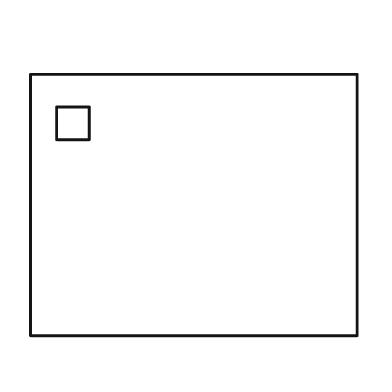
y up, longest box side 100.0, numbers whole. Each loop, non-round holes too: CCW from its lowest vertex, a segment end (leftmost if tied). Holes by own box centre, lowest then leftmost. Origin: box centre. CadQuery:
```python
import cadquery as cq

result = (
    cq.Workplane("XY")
    .moveTo(-50.0, -40.0)
    .lineTo(50.0, -40.0)
    .lineTo(50.0, 40.0)
    .lineTo(-50.0, 40.0)
    .close()
    .moveTo(-42.0, 20.0)
    .lineTo(-32.0, 20.0)
    .lineTo(-32.0, 30.0)
    .lineTo(-42.0, 30.0)
    .close()
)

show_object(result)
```